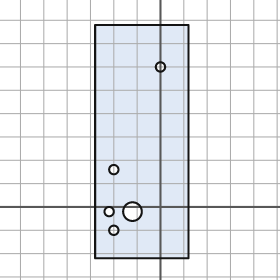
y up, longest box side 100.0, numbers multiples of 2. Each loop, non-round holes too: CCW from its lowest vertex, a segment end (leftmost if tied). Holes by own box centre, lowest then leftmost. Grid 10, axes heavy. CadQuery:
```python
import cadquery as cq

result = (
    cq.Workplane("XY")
    .moveTo(-28.0, -22.0)
    .lineTo(12.0, -22.0)
    .lineTo(12.0, 78.0)
    .lineTo(-28.0, 78.0)
    .close()
    .moveTo(-20.0, -10.0)
    .circle(2.0)
    .moveTo(-22.0, -2.0)
    .circle(2.0)
    .moveTo(-12.0, -2.0)
    .circle(4.0)
    .moveTo(-20.0, 16.0)
    .circle(2.0)
    .moveTo(0.0, 60.0)
    .circle(2.0)
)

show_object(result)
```